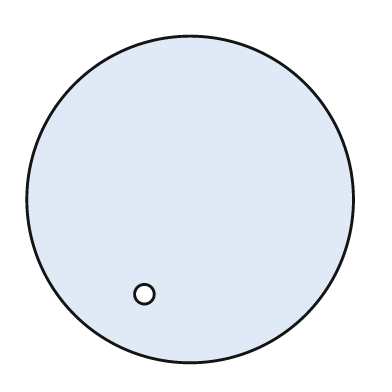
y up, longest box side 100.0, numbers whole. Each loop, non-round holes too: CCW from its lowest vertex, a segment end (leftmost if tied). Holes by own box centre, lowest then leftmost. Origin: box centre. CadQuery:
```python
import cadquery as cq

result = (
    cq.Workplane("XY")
    .moveTo(0.0, 0.0)
    .circle(50.0)
    .moveTo(-14.0, -29.0)
    .circle(3.0)
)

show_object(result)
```